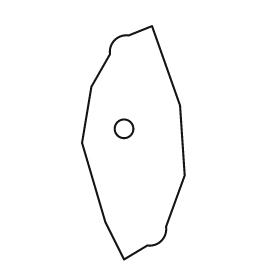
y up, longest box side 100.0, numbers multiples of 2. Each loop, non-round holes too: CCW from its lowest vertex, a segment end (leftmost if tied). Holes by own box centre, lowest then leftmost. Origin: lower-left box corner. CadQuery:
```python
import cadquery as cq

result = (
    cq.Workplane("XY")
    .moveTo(18.0, 0.0)
    .lineTo(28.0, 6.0)
    .threePointArc((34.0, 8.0), (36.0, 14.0))
    .lineTo(44.0, 36.0)
    .lineTo(42.0, 66.0)
    .lineTo(30.0, 100.0)
    .lineTo(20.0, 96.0)
    .threePointArc((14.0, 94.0), (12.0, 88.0))
    .lineTo(4.0, 74.0)
    .lineTo(0.0, 50.0)
    .lineTo(10.0, 16.0)
    .close()
    .moveTo(18.0, 56.0)
    .circle(4.0)
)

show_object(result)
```